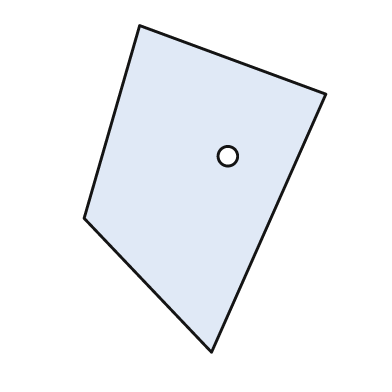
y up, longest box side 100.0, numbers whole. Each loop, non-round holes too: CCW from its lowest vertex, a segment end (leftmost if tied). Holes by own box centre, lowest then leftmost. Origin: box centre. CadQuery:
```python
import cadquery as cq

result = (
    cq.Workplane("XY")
    .moveTo(2.0, -50.0)
    .lineTo(37.0, 29.0)
    .lineTo(-20.0, 50.0)
    .lineTo(-37.0, -9.0)
    .close()
    .moveTo(7.0, 10.0)
    .circle(3.0)
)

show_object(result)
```